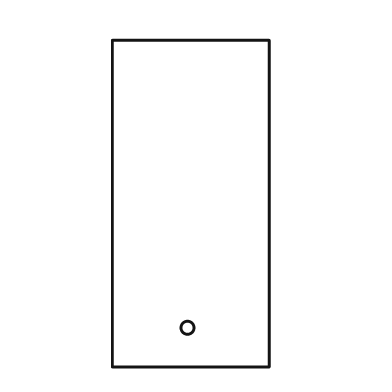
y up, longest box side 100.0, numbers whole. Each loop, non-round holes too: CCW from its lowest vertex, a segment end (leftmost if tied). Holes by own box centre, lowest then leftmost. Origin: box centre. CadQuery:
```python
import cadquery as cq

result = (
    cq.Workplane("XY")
    .moveTo(-24.0, -50.0)
    .lineTo(24.0, -50.0)
    .lineTo(24.0, 50.0)
    .lineTo(-24.0, 50.0)
    .close()
    .moveTo(-1.0, -38.0)
    .circle(2.0)
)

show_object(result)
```